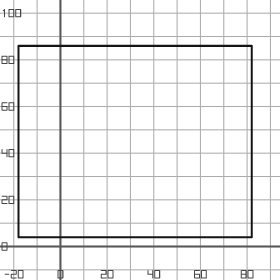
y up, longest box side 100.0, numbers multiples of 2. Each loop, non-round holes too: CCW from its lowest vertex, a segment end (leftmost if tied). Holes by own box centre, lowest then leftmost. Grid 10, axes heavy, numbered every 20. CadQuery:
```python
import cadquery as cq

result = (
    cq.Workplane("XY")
    .moveTo(-18.0, 4.0)
    .lineTo(82.0, 4.0)
    .lineTo(82.0, 86.0)
    .lineTo(-18.0, 86.0)
    .close()
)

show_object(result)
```